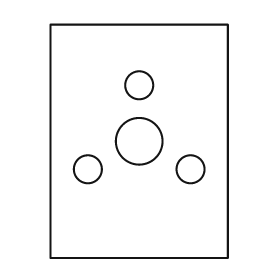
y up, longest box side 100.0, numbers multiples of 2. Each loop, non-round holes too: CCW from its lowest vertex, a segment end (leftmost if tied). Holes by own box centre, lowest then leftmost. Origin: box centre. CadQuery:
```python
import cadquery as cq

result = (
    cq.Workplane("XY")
    .moveTo(-38.0, -50.0)
    .lineTo(38.0, -50.0)
    .lineTo(38.0, 50.0)
    .lineTo(-38.0, 50.0)
    .close()
    .moveTo(-22.0, -12.0)
    .circle(6.0)
    .moveTo(22.0, -12.0)
    .circle(6.0)
    .moveTo(0.0, 0.0)
    .circle(10.0)
    .moveTo(0.0, 24.0)
    .circle(6.0)
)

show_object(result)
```